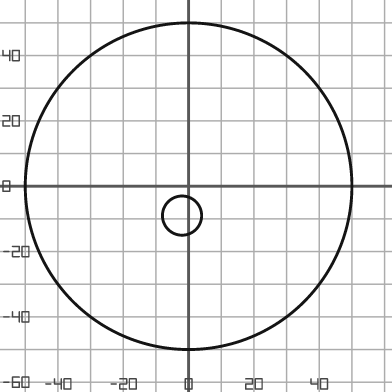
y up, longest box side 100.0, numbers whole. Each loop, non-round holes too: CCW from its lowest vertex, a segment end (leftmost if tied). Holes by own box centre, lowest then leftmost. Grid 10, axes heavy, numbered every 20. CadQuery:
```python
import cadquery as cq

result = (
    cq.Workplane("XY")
    .moveTo(0.0, 0.0)
    .circle(50.0)
    .moveTo(-2.0, -9.0)
    .circle(6.0)
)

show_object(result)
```